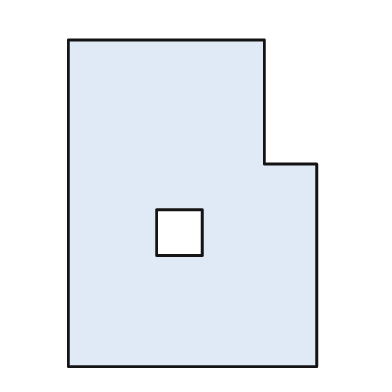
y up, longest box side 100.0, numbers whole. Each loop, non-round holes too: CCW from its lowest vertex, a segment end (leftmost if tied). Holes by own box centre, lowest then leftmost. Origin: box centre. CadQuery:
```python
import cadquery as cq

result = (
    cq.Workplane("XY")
    .moveTo(-38.0, -50.0)
    .lineTo(38.0, -50.0)
    .lineTo(38.0, 12.0)
    .lineTo(22.0, 12.0)
    .lineTo(22.0, 50.0)
    .lineTo(-38.0, 50.0)
    .close()
    .moveTo(-11.0, -16.0)
    .lineTo(3.0, -16.0)
    .lineTo(3.0, -2.0)
    .lineTo(-11.0, -2.0)
    .close()
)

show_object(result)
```